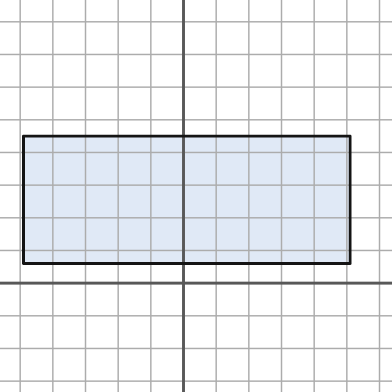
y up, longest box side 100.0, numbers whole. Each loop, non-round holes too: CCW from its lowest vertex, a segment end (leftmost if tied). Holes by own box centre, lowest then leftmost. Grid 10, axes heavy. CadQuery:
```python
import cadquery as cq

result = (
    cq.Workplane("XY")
    .moveTo(-49.0, 6.0)
    .lineTo(51.0, 6.0)
    .lineTo(51.0, 45.0)
    .lineTo(-49.0, 45.0)
    .close()
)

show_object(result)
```